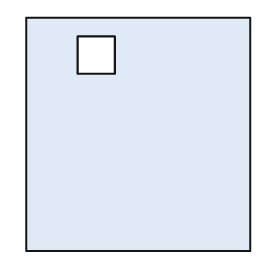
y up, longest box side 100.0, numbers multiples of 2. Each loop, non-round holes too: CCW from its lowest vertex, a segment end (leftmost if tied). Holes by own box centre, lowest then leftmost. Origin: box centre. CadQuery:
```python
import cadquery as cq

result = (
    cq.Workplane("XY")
    .moveTo(-48.0, -50.0)
    .lineTo(48.0, -50.0)
    .lineTo(48.0, 50.0)
    .lineTo(-48.0, 50.0)
    .close()
    .moveTo(-26.0, 26.0)
    .lineTo(-10.0, 26.0)
    .lineTo(-10.0, 42.0)
    .lineTo(-26.0, 42.0)
    .close()
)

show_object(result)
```